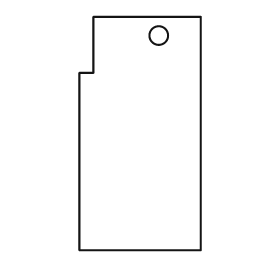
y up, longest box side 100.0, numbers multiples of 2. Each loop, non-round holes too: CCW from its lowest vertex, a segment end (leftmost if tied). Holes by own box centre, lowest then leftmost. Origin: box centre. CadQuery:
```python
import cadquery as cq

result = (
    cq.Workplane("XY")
    .moveTo(-26.0, -50.0)
    .lineTo(26.0, -50.0)
    .lineTo(26.0, 50.0)
    .lineTo(-20.0, 50.0)
    .lineTo(-20.0, 26.0)
    .lineTo(-26.0, 26.0)
    .close()
    .moveTo(8.0, 42.0)
    .circle(4.0)
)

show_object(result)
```